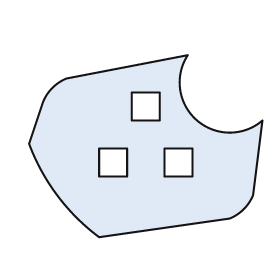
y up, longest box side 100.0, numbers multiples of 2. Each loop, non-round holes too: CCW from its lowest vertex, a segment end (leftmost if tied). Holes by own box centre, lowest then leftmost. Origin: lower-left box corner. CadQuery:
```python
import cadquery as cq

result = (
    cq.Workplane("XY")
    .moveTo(30.0, 0.0)
    .lineTo(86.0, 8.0)
    .threePointArc((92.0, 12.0), (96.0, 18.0))
    .lineTo(100.0, 50.0)
    .threePointArc((72.0, 50.0), (68.0, 78.0))
    .lineTo(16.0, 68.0)
    .threePointArc((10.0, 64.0), (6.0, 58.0))
    .lineTo(0.0, 40.0)
    .threePointArc((12.0, 18.0), (30.0, 0.0))
    .close()
    .moveTo(30.0, 26.0)
    .lineTo(42.0, 26.0)
    .lineTo(42.0, 38.0)
    .lineTo(30.0, 38.0)
    .close()
    .moveTo(58.0, 26.0)
    .lineTo(70.0, 26.0)
    .lineTo(70.0, 38.0)
    .lineTo(58.0, 38.0)
    .close()
    .moveTo(44.0, 50.0)
    .lineTo(56.0, 50.0)
    .lineTo(56.0, 62.0)
    .lineTo(44.0, 62.0)
    .close()
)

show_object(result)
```